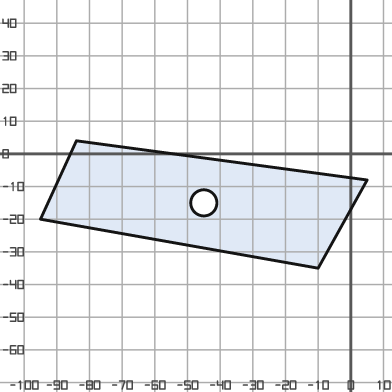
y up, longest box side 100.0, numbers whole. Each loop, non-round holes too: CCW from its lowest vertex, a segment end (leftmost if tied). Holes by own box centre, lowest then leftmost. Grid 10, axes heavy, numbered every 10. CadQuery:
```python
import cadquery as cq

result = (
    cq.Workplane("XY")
    .moveTo(-10.0, -35.0)
    .lineTo(5.0, -8.0)
    .lineTo(-84.0, 4.0)
    .lineTo(-95.0, -20.0)
    .close()
    .moveTo(-45.0, -15.0)
    .circle(4.0)
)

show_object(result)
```